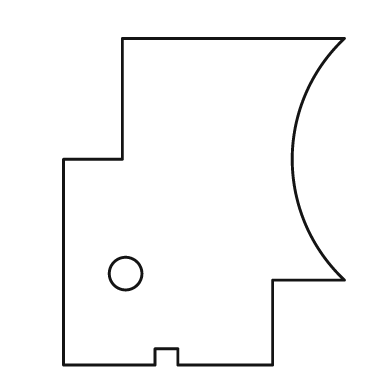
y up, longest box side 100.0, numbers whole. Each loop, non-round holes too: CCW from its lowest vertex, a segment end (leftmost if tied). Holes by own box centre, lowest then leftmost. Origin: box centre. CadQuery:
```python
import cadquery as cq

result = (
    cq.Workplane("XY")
    .moveTo(-43.0, -50.0)
    .lineTo(-15.0, -50.0)
    .lineTo(-15.0, -45.0)
    .lineTo(-8.0, -45.0)
    .lineTo(-8.0, -50.0)
    .lineTo(21.0, -50.0)
    .lineTo(21.0, -24.0)
    .lineTo(43.0, -24.0)
    .threePointArc((27.0, 13.0), (43.0, 50.0))
    .lineTo(-25.0, 50.0)
    .lineTo(-25.0, 13.0)
    .lineTo(-43.0, 13.0)
    .close()
    .moveTo(-24.0, -22.0)
    .circle(5.0)
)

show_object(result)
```